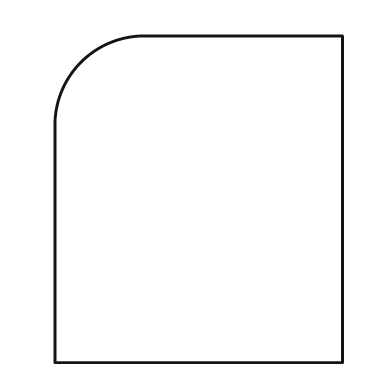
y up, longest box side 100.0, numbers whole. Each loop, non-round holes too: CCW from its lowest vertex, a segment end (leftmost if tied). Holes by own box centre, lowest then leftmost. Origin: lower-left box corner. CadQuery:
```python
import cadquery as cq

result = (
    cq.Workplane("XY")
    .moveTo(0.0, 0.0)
    .lineTo(88.0, 0.0)
    .lineTo(88.0, 100.0)
    .lineTo(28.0, 100.0)
    .threePointArc((8.0, 92.0), (0.0, 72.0))
    .close()
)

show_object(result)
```